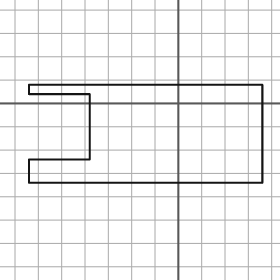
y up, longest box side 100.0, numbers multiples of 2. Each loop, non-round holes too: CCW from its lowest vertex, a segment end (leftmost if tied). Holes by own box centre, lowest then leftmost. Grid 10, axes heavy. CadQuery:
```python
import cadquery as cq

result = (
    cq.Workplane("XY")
    .moveTo(-64.0, -34.0)
    .lineTo(36.0, -34.0)
    .lineTo(36.0, 8.0)
    .lineTo(-64.0, 8.0)
    .lineTo(-64.0, 4.0)
    .lineTo(-38.0, 4.0)
    .lineTo(-38.0, -24.0)
    .lineTo(-64.0, -24.0)
    .close()
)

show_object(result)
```